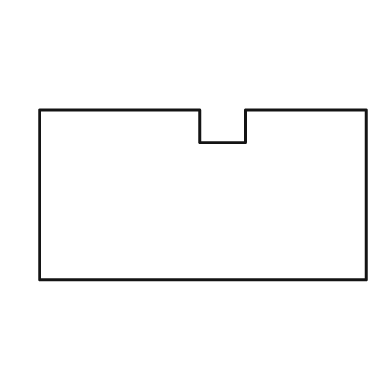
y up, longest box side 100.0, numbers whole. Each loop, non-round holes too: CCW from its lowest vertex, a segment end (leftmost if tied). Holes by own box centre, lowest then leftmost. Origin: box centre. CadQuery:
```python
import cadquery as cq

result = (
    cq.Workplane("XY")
    .moveTo(-50.0, -26.0)
    .lineTo(50.0, -26.0)
    .lineTo(50.0, 26.0)
    .lineTo(13.0, 26.0)
    .lineTo(13.0, 16.0)
    .lineTo(-1.0, 16.0)
    .lineTo(-1.0, 26.0)
    .lineTo(-50.0, 26.0)
    .close()
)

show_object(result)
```